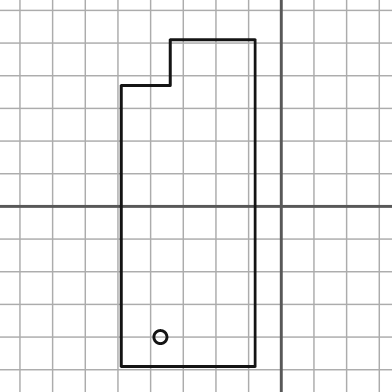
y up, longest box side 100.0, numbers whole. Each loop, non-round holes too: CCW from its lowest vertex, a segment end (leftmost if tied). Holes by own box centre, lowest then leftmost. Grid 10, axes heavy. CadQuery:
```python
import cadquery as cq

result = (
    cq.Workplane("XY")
    .moveTo(-49.0, -49.0)
    .lineTo(-8.0, -49.0)
    .lineTo(-8.0, 51.0)
    .lineTo(-34.0, 51.0)
    .lineTo(-34.0, 37.0)
    .lineTo(-49.0, 37.0)
    .close()
    .moveTo(-37.0, -40.0)
    .circle(2.0)
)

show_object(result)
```